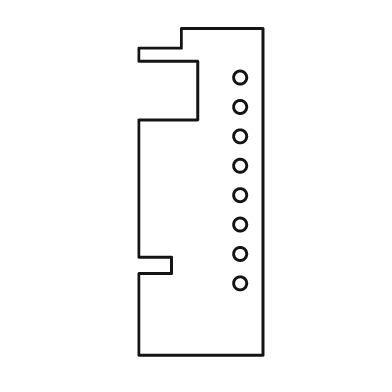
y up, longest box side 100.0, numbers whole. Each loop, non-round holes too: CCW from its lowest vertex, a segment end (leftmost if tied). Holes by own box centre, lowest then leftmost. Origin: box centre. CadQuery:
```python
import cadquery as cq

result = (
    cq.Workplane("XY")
    .moveTo(-19.0, -50.0)
    .lineTo(19.0, -50.0)
    .lineTo(19.0, 50.0)
    .lineTo(-6.0, 50.0)
    .lineTo(-6.0, 44.0)
    .lineTo(-19.0, 44.0)
    .lineTo(-19.0, 40.0)
    .lineTo(-1.0, 40.0)
    .lineTo(-1.0, 22.0)
    .lineTo(-19.0, 22.0)
    .lineTo(-19.0, -20.0)
    .lineTo(-9.0, -20.0)
    .lineTo(-9.0, -25.0)
    .lineTo(-19.0, -25.0)
    .close()
    .moveTo(12.0, -28.0)
    .circle(2.0)
    .moveTo(12.0, -19.0)
    .circle(2.0)
    .moveTo(12.0, -10.0)
    .circle(2.0)
    .moveTo(12.0, -1.0)
    .circle(2.0)
    .moveTo(12.0, 8.0)
    .circle(2.0)
    .moveTo(12.0, 17.0)
    .circle(2.0)
    .moveTo(12.0, 26.0)
    .circle(2.0)
    .moveTo(12.0, 35.0)
    .circle(2.0)
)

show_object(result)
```